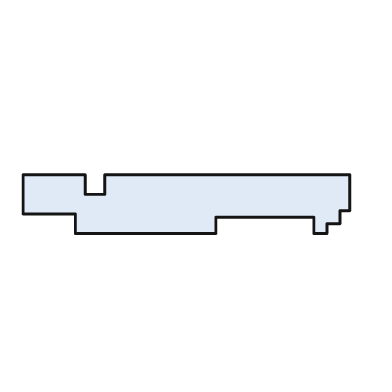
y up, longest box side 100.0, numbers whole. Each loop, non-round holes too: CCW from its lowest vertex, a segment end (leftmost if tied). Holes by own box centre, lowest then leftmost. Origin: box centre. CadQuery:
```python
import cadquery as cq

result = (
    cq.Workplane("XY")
    .moveTo(-34.0, -9.0)
    .lineTo(9.0, -9.0)
    .lineTo(9.0, -4.0)
    .lineTo(39.0, -4.0)
    .lineTo(39.0, -9.0)
    .lineTo(43.0, -9.0)
    .lineTo(43.0, -6.0)
    .lineTo(47.0, -6.0)
    .lineTo(47.0, -2.0)
    .lineTo(50.0, -2.0)
    .lineTo(50.0, 9.0)
    .lineTo(-25.0, 9.0)
    .lineTo(-25.0, 3.0)
    .lineTo(-31.0, 3.0)
    .lineTo(-31.0, 9.0)
    .lineTo(-50.0, 9.0)
    .lineTo(-50.0, -3.0)
    .lineTo(-34.0, -3.0)
    .close()
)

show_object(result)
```